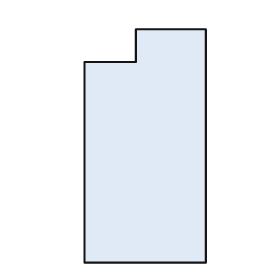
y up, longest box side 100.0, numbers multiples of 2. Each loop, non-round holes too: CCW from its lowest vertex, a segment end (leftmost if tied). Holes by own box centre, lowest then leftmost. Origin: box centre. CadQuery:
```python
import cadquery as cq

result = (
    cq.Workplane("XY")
    .moveTo(-26.0, -50.0)
    .lineTo(26.0, -50.0)
    .lineTo(26.0, 50.0)
    .lineTo(-4.0, 50.0)
    .lineTo(-4.0, 36.0)
    .lineTo(-26.0, 36.0)
    .close()
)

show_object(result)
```